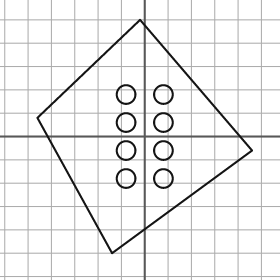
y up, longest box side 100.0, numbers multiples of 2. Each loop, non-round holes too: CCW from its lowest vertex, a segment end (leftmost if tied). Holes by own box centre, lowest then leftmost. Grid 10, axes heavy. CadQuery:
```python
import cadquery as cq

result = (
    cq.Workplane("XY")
    .moveTo(-14.0, -50.0)
    .lineTo(46.0, -6.0)
    .lineTo(-2.0, 50.0)
    .lineTo(-46.0, 8.0)
    .close()
    .moveTo(-8.0, -18.0)
    .circle(4.0)
    .moveTo(8.0, -18.0)
    .circle(4.0)
    .moveTo(-8.0, -6.0)
    .circle(4.0)
    .moveTo(8.0, -6.0)
    .circle(4.0)
    .moveTo(-8.0, 6.0)
    .circle(4.0)
    .moveTo(8.0, 6.0)
    .circle(4.0)
    .moveTo(-8.0, 18.0)
    .circle(4.0)
    .moveTo(8.0, 18.0)
    .circle(4.0)
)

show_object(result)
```